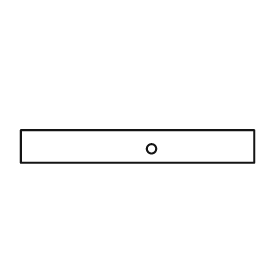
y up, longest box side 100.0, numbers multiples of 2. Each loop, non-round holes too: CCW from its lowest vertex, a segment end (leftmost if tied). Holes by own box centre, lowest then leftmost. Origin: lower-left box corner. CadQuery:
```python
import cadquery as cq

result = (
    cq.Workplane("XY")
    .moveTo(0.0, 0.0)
    .lineTo(100.0, 0.0)
    .lineTo(100.0, 14.0)
    .lineTo(0.0, 14.0)
    .close()
    .moveTo(56.0, 6.0)
    .circle(2.0)
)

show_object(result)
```